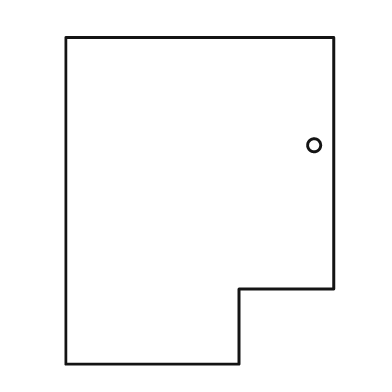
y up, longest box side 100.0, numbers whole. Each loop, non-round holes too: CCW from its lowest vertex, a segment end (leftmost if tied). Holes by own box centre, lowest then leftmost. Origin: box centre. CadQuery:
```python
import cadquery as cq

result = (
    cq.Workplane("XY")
    .moveTo(-41.0, -50.0)
    .lineTo(12.0, -50.0)
    .lineTo(12.0, -27.0)
    .lineTo(41.0, -27.0)
    .lineTo(41.0, 50.0)
    .lineTo(-41.0, 50.0)
    .close()
    .moveTo(35.0, 17.0)
    .circle(2.0)
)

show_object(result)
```